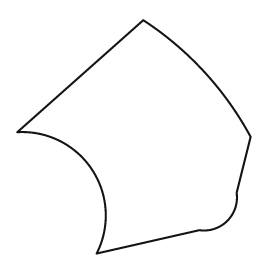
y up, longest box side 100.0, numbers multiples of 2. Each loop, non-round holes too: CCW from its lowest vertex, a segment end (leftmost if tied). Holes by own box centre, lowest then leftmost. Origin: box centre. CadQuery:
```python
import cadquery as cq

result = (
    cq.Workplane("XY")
    .moveTo(-16.0, -50.0)
    .lineTo(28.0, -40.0)
    .threePointArc((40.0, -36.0), (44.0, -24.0))
    .lineTo(50.0, 0.0)
    .threePointArc((30.0, 28.0), (4.0, 50.0))
    .lineTo(-50.0, 2.0)
    .threePointArc((-18.0, -14.0), (-16.0, -50.0))
    .close()
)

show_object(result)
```